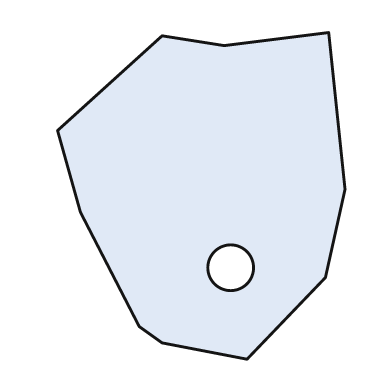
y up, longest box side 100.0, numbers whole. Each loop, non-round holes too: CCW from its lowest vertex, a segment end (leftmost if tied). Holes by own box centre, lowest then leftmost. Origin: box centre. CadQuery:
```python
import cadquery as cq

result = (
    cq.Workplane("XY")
    .moveTo(14.0, -50.0)
    .lineTo(38.0, -25.0)
    .lineTo(44.0, 2.0)
    .lineTo(39.0, 50.0)
    .lineTo(7.0, 46.0)
    .lineTo(-12.0, 49.0)
    .lineTo(-44.0, 20.0)
    .lineTo(-37.0, -5.0)
    .lineTo(-19.0, -40.0)
    .lineTo(-12.0, -45.0)
    .close()
    .moveTo(9.0, -22.0)
    .circle(7.0)
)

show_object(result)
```